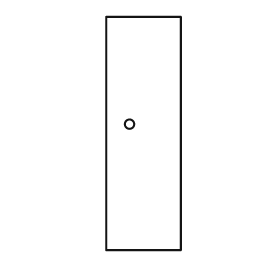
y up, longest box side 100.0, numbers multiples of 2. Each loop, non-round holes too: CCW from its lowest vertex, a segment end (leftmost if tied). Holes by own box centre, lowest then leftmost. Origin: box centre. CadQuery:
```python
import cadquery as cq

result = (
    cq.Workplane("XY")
    .moveTo(-16.0, -50.0)
    .lineTo(16.0, -50.0)
    .lineTo(16.0, 50.0)
    .lineTo(-16.0, 50.0)
    .close()
    .moveTo(-6.0, 4.0)
    .circle(2.0)
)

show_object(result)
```